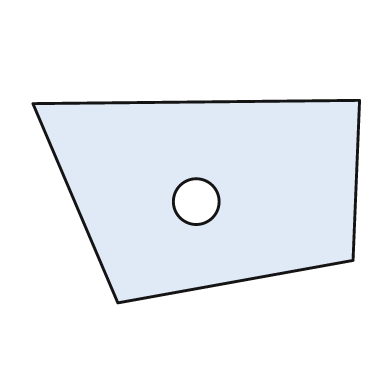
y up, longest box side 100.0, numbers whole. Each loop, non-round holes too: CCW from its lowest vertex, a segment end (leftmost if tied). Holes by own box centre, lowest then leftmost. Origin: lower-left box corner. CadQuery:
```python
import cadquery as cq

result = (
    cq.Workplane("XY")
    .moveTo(26.0, 0.0)
    .lineTo(98.0, 13.0)
    .lineTo(100.0, 62.0)
    .lineTo(0.0, 61.0)
    .close()
    .moveTo(50.0, 31.0)
    .circle(7.0)
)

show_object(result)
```